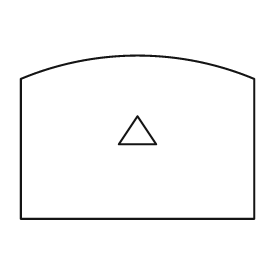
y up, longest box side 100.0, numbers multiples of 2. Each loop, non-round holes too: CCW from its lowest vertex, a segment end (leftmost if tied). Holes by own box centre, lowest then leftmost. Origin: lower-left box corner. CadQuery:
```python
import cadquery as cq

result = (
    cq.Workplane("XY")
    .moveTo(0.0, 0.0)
    .lineTo(100.0, 0.0)
    .lineTo(100.0, 60.0)
    .threePointArc((50.0, 70.0), (0.0, 60.0))
    .close()
    .moveTo(42.0, 32.0)
    .lineTo(58.0, 32.0)
    .lineTo(50.0, 44.0)
    .close()
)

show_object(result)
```